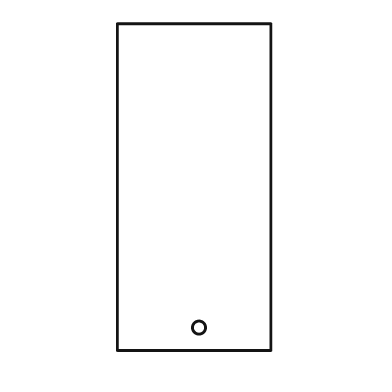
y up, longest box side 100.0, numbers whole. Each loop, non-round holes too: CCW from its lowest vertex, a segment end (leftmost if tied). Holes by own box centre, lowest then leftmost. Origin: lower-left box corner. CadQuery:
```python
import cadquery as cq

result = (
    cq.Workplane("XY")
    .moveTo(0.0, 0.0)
    .lineTo(47.0, 0.0)
    .lineTo(47.0, 100.0)
    .lineTo(0.0, 100.0)
    .close()
    .moveTo(25.0, 7.0)
    .circle(2.0)
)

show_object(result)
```